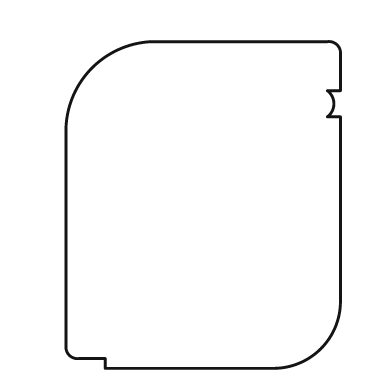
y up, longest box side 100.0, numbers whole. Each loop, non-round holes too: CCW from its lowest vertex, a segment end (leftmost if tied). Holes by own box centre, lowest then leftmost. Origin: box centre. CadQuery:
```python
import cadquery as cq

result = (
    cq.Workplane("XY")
    .moveTo(-30.0, -50.0)
    .lineTo(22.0, -50.0)
    .threePointArc((36.0, -44.0), (42.0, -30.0))
    .lineTo(42.0, 27.0)
    .lineTo(38.0, 27.0)
    .threePointArc((40.0, 31.0), (38.0, 35.0))
    .lineTo(42.0, 35.0)
    .lineTo(42.0, 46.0)
    .threePointArc((41.0, 49.0), (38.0, 50.0))
    .lineTo(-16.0, 50.0)
    .threePointArc((-34.0, 42.0), (-42.0, 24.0))
    .lineTo(-42.0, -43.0)
    .threePointArc((-41.0, -46.0), (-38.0, -47.0))
    .lineTo(-30.0, -47.0)
    .close()
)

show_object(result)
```